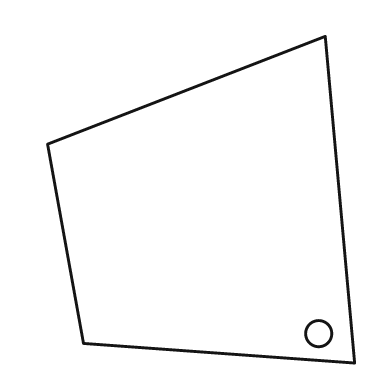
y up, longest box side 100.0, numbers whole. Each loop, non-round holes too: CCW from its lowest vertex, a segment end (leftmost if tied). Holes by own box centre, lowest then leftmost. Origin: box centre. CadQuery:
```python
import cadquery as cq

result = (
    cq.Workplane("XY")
    .moveTo(47.0, -50.0)
    .lineTo(38.0, 50.0)
    .lineTo(-47.0, 17.0)
    .lineTo(-36.0, -44.0)
    .close()
    .moveTo(36.0, -41.0)
    .circle(4.0)
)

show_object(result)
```